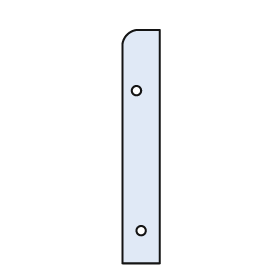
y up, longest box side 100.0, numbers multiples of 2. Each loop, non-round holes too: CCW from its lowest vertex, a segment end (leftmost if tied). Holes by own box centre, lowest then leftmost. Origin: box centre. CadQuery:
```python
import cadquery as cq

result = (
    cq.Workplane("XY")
    .moveTo(-8.0, -50.0)
    .lineTo(8.0, -50.0)
    .lineTo(8.0, 50.0)
    .lineTo(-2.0, 50.0)
    .threePointArc((-6.0, 48.0), (-8.0, 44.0))
    .close()
    .moveTo(0.0, -36.0)
    .circle(2.0)
    .moveTo(-2.0, 24.0)
    .circle(2.0)
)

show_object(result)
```